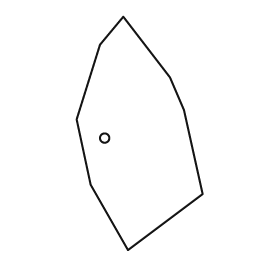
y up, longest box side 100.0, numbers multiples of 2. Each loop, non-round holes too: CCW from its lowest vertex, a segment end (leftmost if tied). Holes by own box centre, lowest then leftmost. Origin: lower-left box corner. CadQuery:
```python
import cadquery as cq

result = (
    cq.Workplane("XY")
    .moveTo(22.0, 0.0)
    .lineTo(54.0, 24.0)
    .lineTo(46.0, 60.0)
    .lineTo(40.0, 74.0)
    .lineTo(20.0, 100.0)
    .lineTo(10.0, 88.0)
    .lineTo(0.0, 56.0)
    .lineTo(6.0, 28.0)
    .close()
    .moveTo(12.0, 48.0)
    .circle(2.0)
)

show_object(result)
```